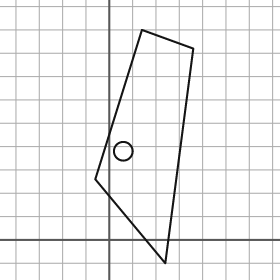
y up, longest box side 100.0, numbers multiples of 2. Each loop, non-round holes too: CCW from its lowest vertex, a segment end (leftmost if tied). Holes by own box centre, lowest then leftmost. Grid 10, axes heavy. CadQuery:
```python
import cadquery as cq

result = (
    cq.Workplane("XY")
    .moveTo(24.0, -10.0)
    .lineTo(36.0, 82.0)
    .lineTo(14.0, 90.0)
    .lineTo(-6.0, 26.0)
    .close()
    .moveTo(6.0, 38.0)
    .circle(4.0)
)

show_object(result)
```